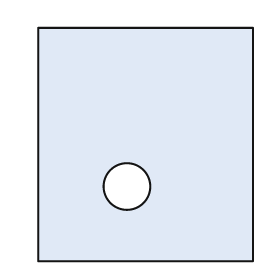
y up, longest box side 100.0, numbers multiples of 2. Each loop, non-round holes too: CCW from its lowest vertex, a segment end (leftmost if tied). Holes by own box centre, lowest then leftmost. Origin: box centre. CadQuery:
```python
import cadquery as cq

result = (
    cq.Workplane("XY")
    .moveTo(-46.0, -50.0)
    .lineTo(46.0, -50.0)
    .lineTo(46.0, 50.0)
    .lineTo(-46.0, 50.0)
    .close()
    .moveTo(-8.0, -18.0)
    .circle(10.0)
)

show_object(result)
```